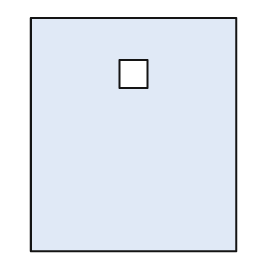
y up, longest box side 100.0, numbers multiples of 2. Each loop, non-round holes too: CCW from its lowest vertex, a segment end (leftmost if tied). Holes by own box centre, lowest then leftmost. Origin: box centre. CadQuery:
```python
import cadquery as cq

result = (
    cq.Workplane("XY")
    .moveTo(-44.0, -50.0)
    .lineTo(44.0, -50.0)
    .lineTo(44.0, 50.0)
    .lineTo(-44.0, 50.0)
    .close()
    .moveTo(-6.0, 20.0)
    .lineTo(6.0, 20.0)
    .lineTo(6.0, 32.0)
    .lineTo(-6.0, 32.0)
    .close()
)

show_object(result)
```